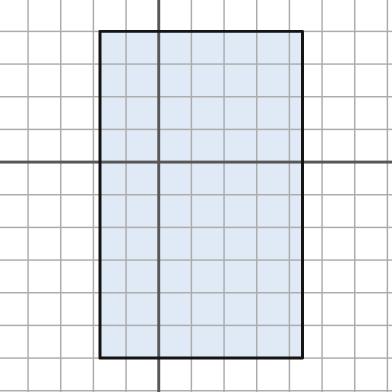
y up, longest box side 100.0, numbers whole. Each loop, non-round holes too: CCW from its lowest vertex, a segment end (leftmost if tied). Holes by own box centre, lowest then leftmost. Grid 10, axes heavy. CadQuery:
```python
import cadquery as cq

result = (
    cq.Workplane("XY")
    .moveTo(-18.0, -60.0)
    .lineTo(44.0, -60.0)
    .lineTo(44.0, 40.0)
    .lineTo(-18.0, 40.0)
    .close()
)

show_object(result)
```